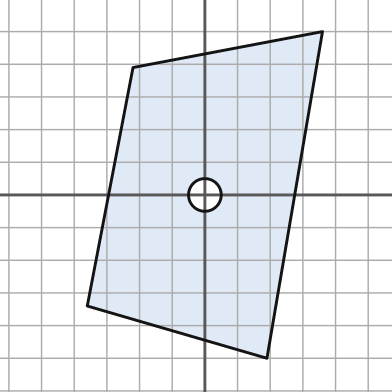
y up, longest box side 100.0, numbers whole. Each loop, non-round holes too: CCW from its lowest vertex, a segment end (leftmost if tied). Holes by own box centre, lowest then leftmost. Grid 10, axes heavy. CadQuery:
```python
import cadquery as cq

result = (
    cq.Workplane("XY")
    .moveTo(19.0, -50.0)
    .lineTo(36.0, 50.0)
    .lineTo(-22.0, 39.0)
    .lineTo(-36.0, -34.0)
    .close()
    .moveTo(0.0, 0.0)
    .circle(5.0)
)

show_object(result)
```